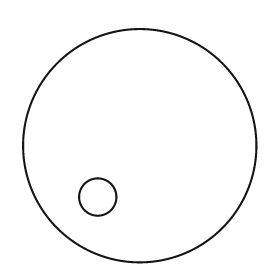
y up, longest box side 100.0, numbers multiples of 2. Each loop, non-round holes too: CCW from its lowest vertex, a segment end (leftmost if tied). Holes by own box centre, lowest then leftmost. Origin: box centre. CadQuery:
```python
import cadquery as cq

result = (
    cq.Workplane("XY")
    .moveTo(0.0, 0.0)
    .circle(50.0)
    .moveTo(-18.0, -22.0)
    .circle(8.0)
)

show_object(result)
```